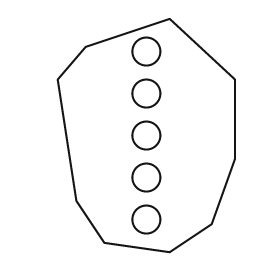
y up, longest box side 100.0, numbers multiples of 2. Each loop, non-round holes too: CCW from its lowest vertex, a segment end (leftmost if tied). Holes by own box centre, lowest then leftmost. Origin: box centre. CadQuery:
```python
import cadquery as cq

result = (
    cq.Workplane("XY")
    .moveTo(10.0, -50.0)
    .lineTo(28.0, -38.0)
    .lineTo(38.0, -10.0)
    .lineTo(38.0, 24.0)
    .lineTo(10.0, 50.0)
    .lineTo(-26.0, 38.0)
    .lineTo(-38.0, 24.0)
    .lineTo(-30.0, -28.0)
    .lineTo(-18.0, -46.0)
    .close()
    .moveTo(0.0, -36.0)
    .circle(6.0)
    .moveTo(0.0, -18.0)
    .circle(6.0)
    .moveTo(0.0, 0.0)
    .circle(6.0)
    .moveTo(0.0, 18.0)
    .circle(6.0)
    .moveTo(0.0, 36.0)
    .circle(6.0)
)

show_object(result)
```